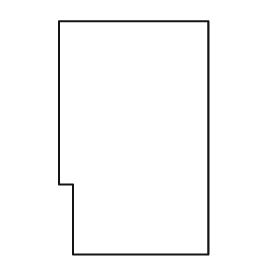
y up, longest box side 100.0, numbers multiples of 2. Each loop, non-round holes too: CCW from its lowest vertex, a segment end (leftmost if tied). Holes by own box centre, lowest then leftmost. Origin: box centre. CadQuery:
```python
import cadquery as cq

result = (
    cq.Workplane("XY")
    .moveTo(-26.0, -50.0)
    .lineTo(32.0, -50.0)
    .lineTo(32.0, 50.0)
    .lineTo(-32.0, 50.0)
    .lineTo(-32.0, -20.0)
    .lineTo(-26.0, -20.0)
    .close()
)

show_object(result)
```